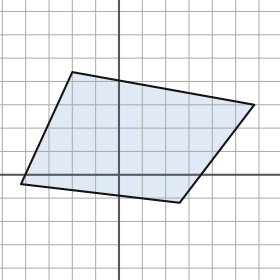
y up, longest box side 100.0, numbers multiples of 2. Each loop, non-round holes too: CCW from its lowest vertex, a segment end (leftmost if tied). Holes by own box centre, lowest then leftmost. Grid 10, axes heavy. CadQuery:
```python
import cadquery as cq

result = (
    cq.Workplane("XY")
    .moveTo(26.0, -12.0)
    .lineTo(58.0, 30.0)
    .lineTo(-20.0, 44.0)
    .lineTo(-42.0, -4.0)
    .close()
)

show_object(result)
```